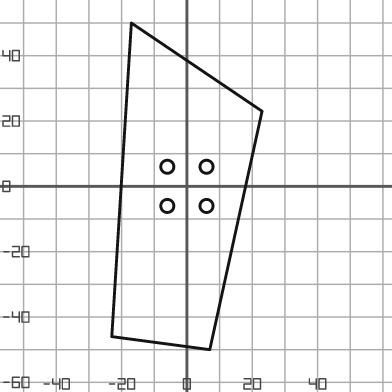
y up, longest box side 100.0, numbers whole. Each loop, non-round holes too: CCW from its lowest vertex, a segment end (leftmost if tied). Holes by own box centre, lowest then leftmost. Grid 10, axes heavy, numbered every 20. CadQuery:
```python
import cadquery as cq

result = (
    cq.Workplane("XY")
    .moveTo(7.0, -50.0)
    .lineTo(23.0, 23.0)
    .lineTo(-17.0, 50.0)
    .lineTo(-23.0, -46.0)
    .close()
    .moveTo(-6.0, -6.0)
    .circle(2.0)
    .moveTo(6.0, -6.0)
    .circle(2.0)
    .moveTo(-6.0, 6.0)
    .circle(2.0)
    .moveTo(6.0, 6.0)
    .circle(2.0)
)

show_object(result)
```